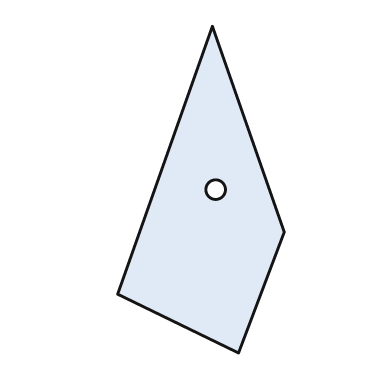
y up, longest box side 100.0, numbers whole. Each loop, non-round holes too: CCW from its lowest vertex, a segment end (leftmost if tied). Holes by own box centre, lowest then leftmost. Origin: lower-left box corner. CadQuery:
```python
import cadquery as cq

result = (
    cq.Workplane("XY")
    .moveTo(37.0, 0.0)
    .lineTo(51.0, 37.0)
    .lineTo(29.0, 100.0)
    .lineTo(0.0, 18.0)
    .close()
    .moveTo(30.0, 50.0)
    .circle(3.0)
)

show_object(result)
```